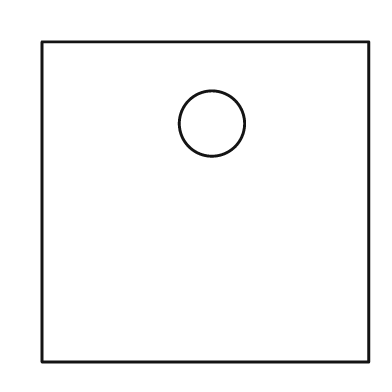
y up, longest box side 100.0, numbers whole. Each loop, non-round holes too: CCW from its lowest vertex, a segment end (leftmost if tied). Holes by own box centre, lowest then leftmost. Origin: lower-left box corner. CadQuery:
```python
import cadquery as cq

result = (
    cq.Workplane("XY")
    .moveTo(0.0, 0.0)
    .lineTo(100.0, 0.0)
    .lineTo(100.0, 98.0)
    .lineTo(0.0, 98.0)
    .close()
    .moveTo(52.0, 73.0)
    .circle(10.0)
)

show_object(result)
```